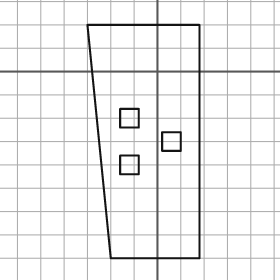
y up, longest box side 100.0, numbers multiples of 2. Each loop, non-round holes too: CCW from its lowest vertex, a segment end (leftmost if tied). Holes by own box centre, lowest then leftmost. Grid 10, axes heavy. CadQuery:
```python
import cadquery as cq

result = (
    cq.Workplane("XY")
    .moveTo(-20.0, -80.0)
    .lineTo(18.0, -80.0)
    .lineTo(18.0, 20.0)
    .lineTo(-30.0, 20.0)
    .close()
    .moveTo(-16.0, -44.0)
    .lineTo(-8.0, -44.0)
    .lineTo(-8.0, -36.0)
    .lineTo(-16.0, -36.0)
    .close()
    .moveTo(2.0, -34.0)
    .lineTo(10.0, -34.0)
    .lineTo(10.0, -26.0)
    .lineTo(2.0, -26.0)
    .close()
    .moveTo(-16.0, -24.0)
    .lineTo(-8.0, -24.0)
    .lineTo(-8.0, -16.0)
    .lineTo(-16.0, -16.0)
    .close()
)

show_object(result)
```